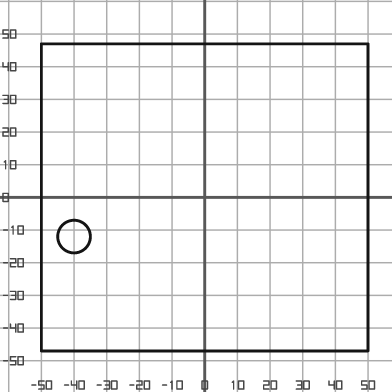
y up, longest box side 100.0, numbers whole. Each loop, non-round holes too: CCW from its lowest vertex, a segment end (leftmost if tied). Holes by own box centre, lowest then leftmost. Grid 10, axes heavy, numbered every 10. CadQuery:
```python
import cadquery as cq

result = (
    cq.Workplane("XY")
    .moveTo(-50.0, -47.0)
    .lineTo(50.0, -47.0)
    .lineTo(50.0, 47.0)
    .lineTo(-50.0, 47.0)
    .close()
    .moveTo(-40.0, -12.0)
    .circle(5.0)
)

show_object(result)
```